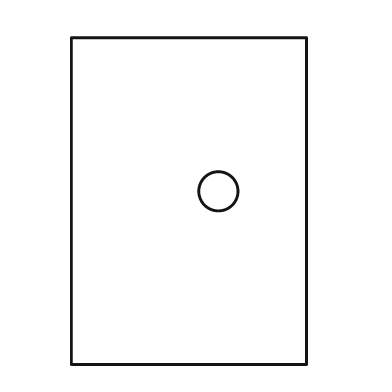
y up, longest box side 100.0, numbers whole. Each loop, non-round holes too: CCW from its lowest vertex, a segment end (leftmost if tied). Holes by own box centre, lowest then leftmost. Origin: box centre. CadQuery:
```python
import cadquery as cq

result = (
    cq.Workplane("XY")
    .moveTo(-36.0, -50.0)
    .lineTo(36.0, -50.0)
    .lineTo(36.0, 50.0)
    .lineTo(-36.0, 50.0)
    .close()
    .moveTo(9.0, 3.0)
    .circle(6.0)
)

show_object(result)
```